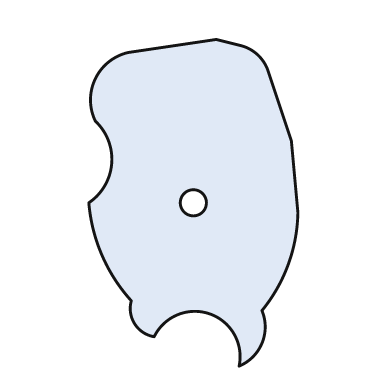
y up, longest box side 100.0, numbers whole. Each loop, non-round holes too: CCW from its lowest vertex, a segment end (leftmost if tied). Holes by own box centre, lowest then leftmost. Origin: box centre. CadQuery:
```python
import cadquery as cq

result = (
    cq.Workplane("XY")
    .moveTo(14.0, -50.0)
    .threePointArc((21.0, -43.0), (21.0, -33.0))
    .threePointArc((29.0, -19.0), (32.0, -3.0))
    .lineTo(30.0, 19.0)
    .lineTo(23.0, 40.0)
    .threePointArc((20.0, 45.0), (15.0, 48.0))
    .lineTo(7.0, 50.0)
    .lineTo(-20.0, 46.0)
    .threePointArc((-30.0, 38.0), (-30.0, 25.0))
    .threePointArc((-25.0, 12.0), (-32.0, 0.0))
    .threePointArc((-28.0, -16.0), (-19.0, -30.0))
    .threePointArc((-18.0, -37.0), (-12.0, -41.0))
    .threePointArc((5.0, -34.0), (14.0, -50.0))
    .close()
    .moveTo(0.0, 0.0)
    .circle(4.0)
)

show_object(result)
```